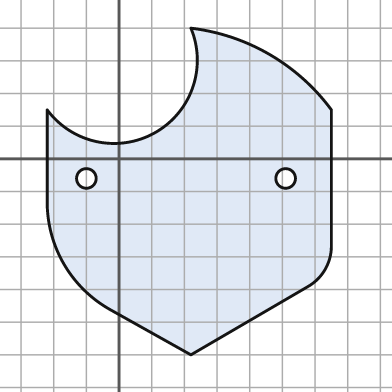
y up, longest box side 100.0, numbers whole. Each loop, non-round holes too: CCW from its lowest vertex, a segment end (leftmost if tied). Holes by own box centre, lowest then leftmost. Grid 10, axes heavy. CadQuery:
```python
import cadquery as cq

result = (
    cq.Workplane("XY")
    .moveTo(22.0, -60.0)
    .lineTo(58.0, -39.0)
    .threePointArc((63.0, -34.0), (65.0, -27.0))
    .lineTo(65.0, 15.0)
    .threePointArc((46.0, 32.0), (22.0, 40.0))
    .threePointArc((11.0, 8.0), (-22.0, 15.0))
    .lineTo(-22.0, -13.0)
    .threePointArc((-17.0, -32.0), (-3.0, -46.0))
    .close()
    .moveTo(-10.0, -6.0)
    .circle(3.0)
    .moveTo(51.0, -6.0)
    .circle(3.0)
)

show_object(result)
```